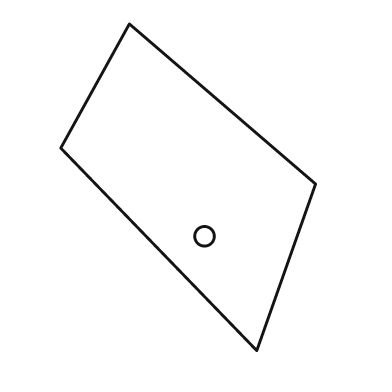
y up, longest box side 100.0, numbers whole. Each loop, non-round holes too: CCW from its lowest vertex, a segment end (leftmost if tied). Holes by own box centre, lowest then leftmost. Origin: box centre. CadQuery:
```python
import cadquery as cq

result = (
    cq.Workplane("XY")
    .moveTo(21.0, -50.0)
    .lineTo(39.0, 1.0)
    .lineTo(-18.0, 50.0)
    .lineTo(-39.0, 12.0)
    .close()
    .moveTo(5.0, -15.0)
    .circle(3.0)
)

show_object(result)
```